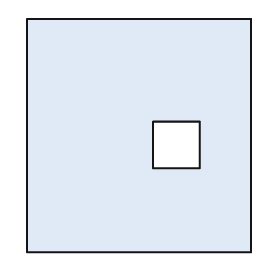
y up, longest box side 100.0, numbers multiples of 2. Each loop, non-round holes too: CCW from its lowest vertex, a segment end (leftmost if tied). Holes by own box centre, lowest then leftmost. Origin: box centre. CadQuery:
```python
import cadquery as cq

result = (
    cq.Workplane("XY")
    .moveTo(-48.0, -50.0)
    .lineTo(48.0, -50.0)
    .lineTo(48.0, 50.0)
    .lineTo(-48.0, 50.0)
    .close()
    .moveTo(6.0, -14.0)
    .lineTo(26.0, -14.0)
    .lineTo(26.0, 6.0)
    .lineTo(6.0, 6.0)
    .close()
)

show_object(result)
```